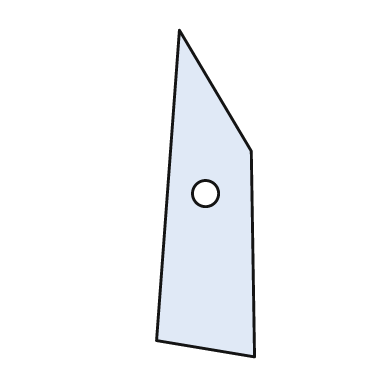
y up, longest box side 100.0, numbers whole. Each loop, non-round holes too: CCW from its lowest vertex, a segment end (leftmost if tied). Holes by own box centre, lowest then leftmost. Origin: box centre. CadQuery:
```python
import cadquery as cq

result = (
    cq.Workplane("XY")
    .moveTo(15.0, -50.0)
    .lineTo(14.0, 13.0)
    .lineTo(-8.0, 50.0)
    .lineTo(-15.0, -45.0)
    .close()
    .moveTo(0.0, 0.0)
    .circle(4.0)
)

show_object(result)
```